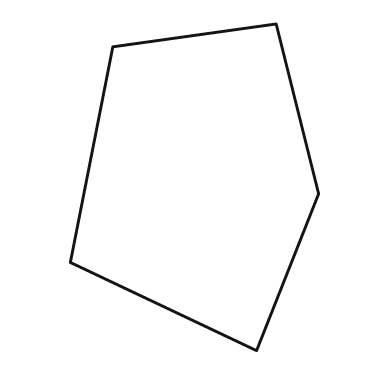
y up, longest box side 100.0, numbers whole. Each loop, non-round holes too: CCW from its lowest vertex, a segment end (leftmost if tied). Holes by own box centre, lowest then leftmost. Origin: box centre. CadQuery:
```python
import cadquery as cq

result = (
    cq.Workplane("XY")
    .moveTo(19.0, -50.0)
    .lineTo(38.0, -2.0)
    .lineTo(25.0, 50.0)
    .lineTo(-25.0, 43.0)
    .lineTo(-38.0, -23.0)
    .close()
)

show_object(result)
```